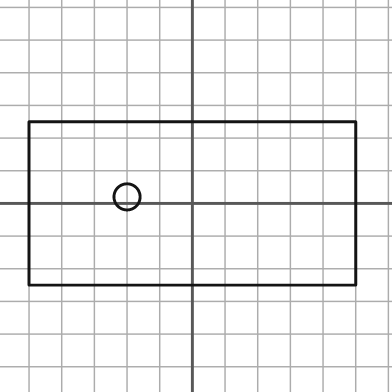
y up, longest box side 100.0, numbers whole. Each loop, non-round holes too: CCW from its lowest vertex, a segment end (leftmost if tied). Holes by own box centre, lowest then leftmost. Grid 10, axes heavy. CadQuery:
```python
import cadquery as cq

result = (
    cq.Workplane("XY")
    .moveTo(-50.0, -25.0)
    .lineTo(50.0, -25.0)
    .lineTo(50.0, 25.0)
    .lineTo(-50.0, 25.0)
    .close()
    .moveTo(-20.0, 2.0)
    .circle(4.0)
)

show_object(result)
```